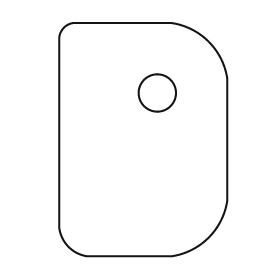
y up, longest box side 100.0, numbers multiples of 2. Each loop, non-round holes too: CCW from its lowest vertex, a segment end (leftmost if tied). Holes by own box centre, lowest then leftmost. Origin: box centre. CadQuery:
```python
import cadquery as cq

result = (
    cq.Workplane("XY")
    .moveTo(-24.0, -50.0)
    .lineTo(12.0, -50.0)
    .threePointArc((28.0, -42.0), (36.0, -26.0))
    .lineTo(36.0, 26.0)
    .threePointArc((28.0, 42.0), (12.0, 50.0))
    .lineTo(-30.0, 50.0)
    .threePointArc((-34.0, 48.0), (-36.0, 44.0))
    .lineTo(-36.0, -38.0)
    .threePointArc((-32.0, -46.0), (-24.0, -50.0))
    .close()
    .moveTo(6.0, 20.0)
    .circle(8.0)
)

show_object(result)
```